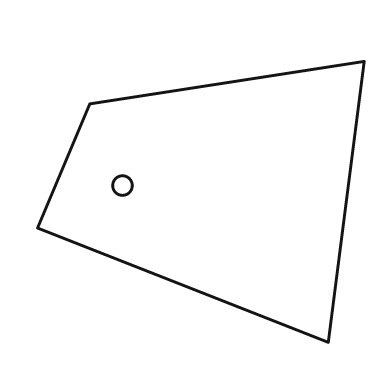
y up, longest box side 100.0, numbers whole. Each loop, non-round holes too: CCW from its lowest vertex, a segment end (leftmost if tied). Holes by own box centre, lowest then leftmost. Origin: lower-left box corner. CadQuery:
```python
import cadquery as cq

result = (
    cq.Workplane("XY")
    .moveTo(89.0, 0.0)
    .lineTo(100.0, 86.0)
    .lineTo(16.0, 73.0)
    .lineTo(0.0, 35.0)
    .close()
    .moveTo(26.0, 48.0)
    .circle(3.0)
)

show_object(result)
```